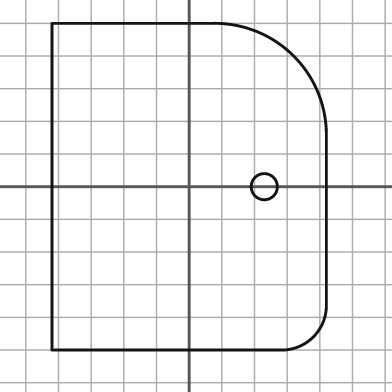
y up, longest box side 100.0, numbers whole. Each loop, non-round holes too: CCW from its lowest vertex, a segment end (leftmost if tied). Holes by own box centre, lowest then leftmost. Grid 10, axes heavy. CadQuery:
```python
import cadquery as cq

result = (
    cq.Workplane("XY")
    .moveTo(-42.0, -50.0)
    .lineTo(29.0, -50.0)
    .threePointArc((38.0, -46.0), (42.0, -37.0))
    .lineTo(42.0, 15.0)
    .threePointArc((32.0, 40.0), (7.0, 50.0))
    .lineTo(-42.0, 50.0)
    .close()
    .moveTo(23.0, 0.0)
    .circle(4.0)
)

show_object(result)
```